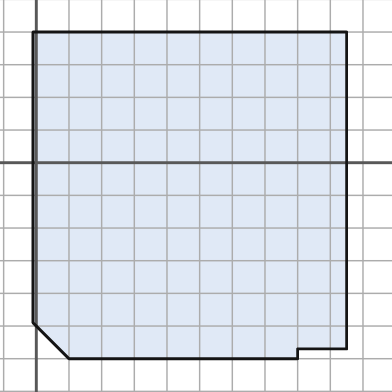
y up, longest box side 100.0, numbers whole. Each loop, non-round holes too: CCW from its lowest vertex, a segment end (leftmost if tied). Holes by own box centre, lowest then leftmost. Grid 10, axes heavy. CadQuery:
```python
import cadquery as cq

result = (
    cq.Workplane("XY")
    .moveTo(10.0, -60.0)
    .lineTo(80.0, -60.0)
    .lineTo(80.0, -57.0)
    .lineTo(95.0, -57.0)
    .lineTo(95.0, 40.0)
    .lineTo(-1.0, 40.0)
    .lineTo(-1.0, -49.0)
    .close()
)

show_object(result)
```